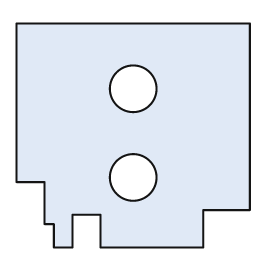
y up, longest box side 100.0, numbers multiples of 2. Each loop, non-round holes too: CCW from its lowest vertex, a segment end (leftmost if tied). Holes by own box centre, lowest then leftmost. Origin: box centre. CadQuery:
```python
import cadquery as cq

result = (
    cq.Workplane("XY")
    .moveTo(-34.0, -48.0)
    .lineTo(-26.0, -48.0)
    .lineTo(-26.0, -34.0)
    .lineTo(-14.0, -34.0)
    .lineTo(-14.0, -48.0)
    .lineTo(30.0, -48.0)
    .lineTo(30.0, -32.0)
    .lineTo(50.0, -32.0)
    .lineTo(50.0, 48.0)
    .lineTo(-50.0, 48.0)
    .lineTo(-50.0, -20.0)
    .lineTo(-38.0, -20.0)
    .lineTo(-38.0, -38.0)
    .lineTo(-34.0, -38.0)
    .close()
    .moveTo(0.0, -18.0)
    .circle(10.0)
    .moveTo(0.0, 20.0)
    .circle(10.0)
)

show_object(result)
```